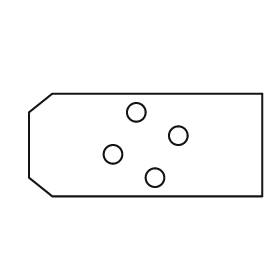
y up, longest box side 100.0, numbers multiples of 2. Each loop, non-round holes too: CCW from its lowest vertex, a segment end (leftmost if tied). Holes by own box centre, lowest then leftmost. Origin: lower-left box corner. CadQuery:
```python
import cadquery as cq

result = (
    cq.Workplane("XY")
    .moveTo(10.0, 0.0)
    .lineTo(100.0, 0.0)
    .lineTo(100.0, 44.0)
    .lineTo(10.0, 44.0)
    .lineTo(0.0, 36.0)
    .lineTo(0.0, 8.0)
    .close()
    .moveTo(54.0, 8.0)
    .circle(4.0)
    .moveTo(36.0, 18.0)
    .circle(4.0)
    .moveTo(64.0, 26.0)
    .circle(4.0)
    .moveTo(46.0, 36.0)
    .circle(4.0)
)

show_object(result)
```